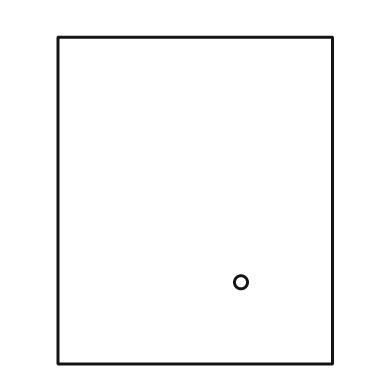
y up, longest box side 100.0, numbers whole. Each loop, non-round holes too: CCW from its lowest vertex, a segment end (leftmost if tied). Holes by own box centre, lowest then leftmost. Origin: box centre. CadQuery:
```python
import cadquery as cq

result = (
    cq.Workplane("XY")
    .moveTo(-42.0, -50.0)
    .lineTo(42.0, -50.0)
    .lineTo(42.0, 50.0)
    .lineTo(-42.0, 50.0)
    .close()
    .moveTo(14.0, -25.0)
    .circle(2.0)
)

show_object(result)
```